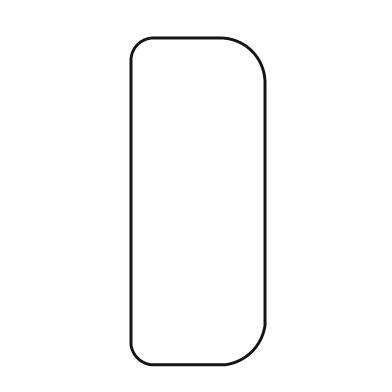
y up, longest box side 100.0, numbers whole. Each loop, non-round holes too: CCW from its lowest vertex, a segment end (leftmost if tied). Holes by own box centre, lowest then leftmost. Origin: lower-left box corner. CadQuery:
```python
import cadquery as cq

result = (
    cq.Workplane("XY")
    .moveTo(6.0, 0.0)
    .lineTo(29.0, 0.0)
    .threePointArc((37.0, 4.0), (41.0, 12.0))
    .lineTo(41.0, 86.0)
    .threePointArc((37.0, 96.0), (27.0, 100.0))
    .lineTo(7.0, 100.0)
    .threePointArc((2.0, 98.0), (0.0, 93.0))
    .lineTo(0.0, 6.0)
    .threePointArc((2.0, 2.0), (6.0, 0.0))
    .close()
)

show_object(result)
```